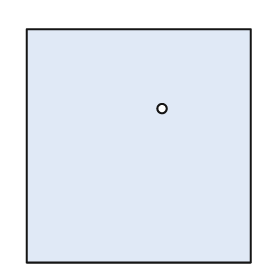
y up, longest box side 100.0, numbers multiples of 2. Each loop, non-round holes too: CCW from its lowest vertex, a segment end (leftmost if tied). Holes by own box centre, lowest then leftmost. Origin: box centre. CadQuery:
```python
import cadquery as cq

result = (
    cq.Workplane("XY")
    .moveTo(-48.0, -50.0)
    .lineTo(48.0, -50.0)
    .lineTo(48.0, 50.0)
    .lineTo(-48.0, 50.0)
    .close()
    .moveTo(10.0, 16.0)
    .circle(2.0)
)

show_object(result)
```